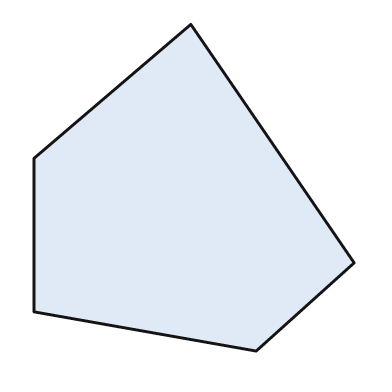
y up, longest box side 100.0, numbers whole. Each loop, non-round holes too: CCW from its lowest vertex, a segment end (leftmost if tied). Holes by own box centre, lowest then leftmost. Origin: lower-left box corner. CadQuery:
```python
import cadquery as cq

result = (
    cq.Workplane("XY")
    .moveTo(68.0, 0.0)
    .lineTo(98.0, 27.0)
    .lineTo(48.0, 100.0)
    .lineTo(0.0, 59.0)
    .lineTo(0.0, 12.0)
    .close()
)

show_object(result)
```